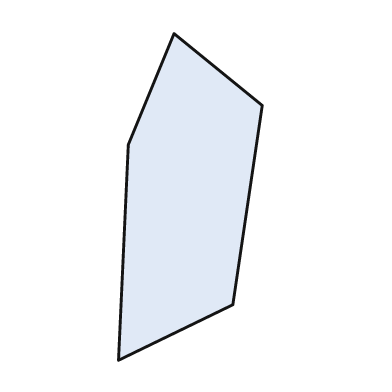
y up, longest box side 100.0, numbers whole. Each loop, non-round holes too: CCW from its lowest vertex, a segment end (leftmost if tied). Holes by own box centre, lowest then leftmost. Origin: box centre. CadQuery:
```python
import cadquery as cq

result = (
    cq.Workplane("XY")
    .moveTo(-22.0, -50.0)
    .lineTo(13.0, -33.0)
    .lineTo(22.0, 28.0)
    .lineTo(-5.0, 50.0)
    .lineTo(-19.0, 16.0)
    .close()
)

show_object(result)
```